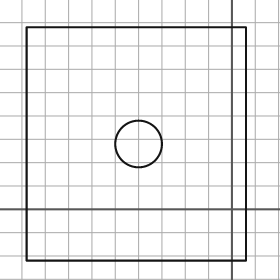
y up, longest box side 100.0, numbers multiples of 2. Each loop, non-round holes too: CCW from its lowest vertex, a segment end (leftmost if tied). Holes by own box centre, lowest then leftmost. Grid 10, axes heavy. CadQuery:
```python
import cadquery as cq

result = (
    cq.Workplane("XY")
    .moveTo(-88.0, -22.0)
    .lineTo(6.0, -22.0)
    .lineTo(6.0, 78.0)
    .lineTo(-88.0, 78.0)
    .close()
    .moveTo(-40.0, 28.0)
    .circle(10.0)
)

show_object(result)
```